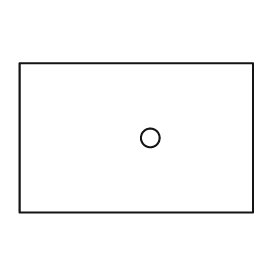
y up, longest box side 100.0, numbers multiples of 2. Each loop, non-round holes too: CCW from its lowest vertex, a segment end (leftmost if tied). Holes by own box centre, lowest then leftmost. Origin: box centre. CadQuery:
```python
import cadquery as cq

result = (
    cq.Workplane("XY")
    .moveTo(-50.0, -32.0)
    .lineTo(50.0, -32.0)
    .lineTo(50.0, 32.0)
    .lineTo(-50.0, 32.0)
    .close()
    .moveTo(6.0, 0.0)
    .circle(4.0)
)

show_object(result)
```